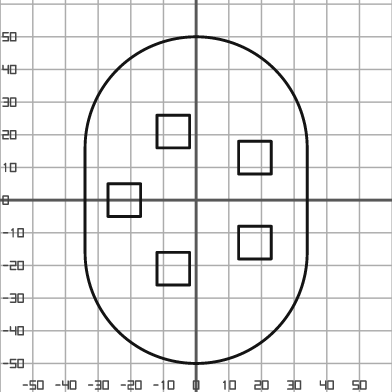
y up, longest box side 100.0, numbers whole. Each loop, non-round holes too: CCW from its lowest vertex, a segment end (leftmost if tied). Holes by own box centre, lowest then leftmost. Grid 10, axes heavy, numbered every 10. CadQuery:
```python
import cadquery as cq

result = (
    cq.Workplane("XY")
    .moveTo(-34.0, -16.0)
    .threePointArc((0.0, -50.0), (34.0, -16.0))
    .lineTo(34.0, 16.0)
    .threePointArc((0.0, 50.0), (-34.0, 16.0))
    .close()
    .moveTo(-12.0, -26.0)
    .lineTo(-2.0, -26.0)
    .lineTo(-2.0, -16.0)
    .lineTo(-12.0, -16.0)
    .close()
    .moveTo(13.0, -18.0)
    .lineTo(23.0, -18.0)
    .lineTo(23.0, -8.0)
    .lineTo(13.0, -8.0)
    .close()
    .moveTo(-27.0, -5.0)
    .lineTo(-17.0, -5.0)
    .lineTo(-17.0, 5.0)
    .lineTo(-27.0, 5.0)
    .close()
    .moveTo(13.0, 8.0)
    .lineTo(23.0, 8.0)
    .lineTo(23.0, 18.0)
    .lineTo(13.0, 18.0)
    .close()
    .moveTo(-12.0, 16.0)
    .lineTo(-2.0, 16.0)
    .lineTo(-2.0, 26.0)
    .lineTo(-12.0, 26.0)
    .close()
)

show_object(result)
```